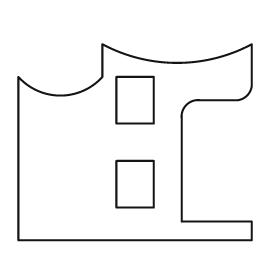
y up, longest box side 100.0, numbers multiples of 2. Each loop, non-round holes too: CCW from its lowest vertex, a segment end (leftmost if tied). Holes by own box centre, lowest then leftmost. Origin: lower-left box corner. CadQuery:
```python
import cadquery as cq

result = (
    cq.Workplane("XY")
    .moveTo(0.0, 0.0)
    .lineTo(100.0, 0.0)
    .lineTo(100.0, 8.0)
    .lineTo(70.0, 8.0)
    .lineTo(70.0, 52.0)
    .threePointArc((72.0, 58.0), (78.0, 60.0))
    .lineTo(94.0, 60.0)
    .threePointArc((98.0, 62.0), (100.0, 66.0))
    .lineTo(100.0, 84.0)
    .threePointArc((68.0, 76.0), (36.0, 84.0))
    .lineTo(36.0, 70.0)
    .threePointArc((18.0, 62.0), (0.0, 70.0))
    .close()
    .moveTo(42.0, 14.0)
    .lineTo(58.0, 14.0)
    .lineTo(58.0, 34.0)
    .lineTo(42.0, 34.0)
    .close()
    .moveTo(42.0, 50.0)
    .lineTo(58.0, 50.0)
    .lineTo(58.0, 70.0)
    .lineTo(42.0, 70.0)
    .close()
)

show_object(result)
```